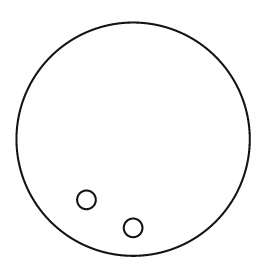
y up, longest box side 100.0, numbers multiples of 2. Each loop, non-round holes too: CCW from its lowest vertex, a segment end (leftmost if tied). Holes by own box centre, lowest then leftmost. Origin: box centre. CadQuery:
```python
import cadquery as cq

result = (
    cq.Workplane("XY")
    .moveTo(0.0, 0.0)
    .circle(50.0)
    .moveTo(0.0, -38.0)
    .circle(4.0)
    .moveTo(-20.0, -26.0)
    .circle(4.0)
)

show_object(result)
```